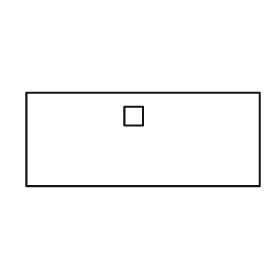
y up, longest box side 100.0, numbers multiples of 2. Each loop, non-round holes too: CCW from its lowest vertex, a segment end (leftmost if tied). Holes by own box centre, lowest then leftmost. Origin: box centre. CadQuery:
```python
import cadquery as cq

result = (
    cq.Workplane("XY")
    .moveTo(-50.0, -20.0)
    .lineTo(50.0, -20.0)
    .lineTo(50.0, 20.0)
    .lineTo(-50.0, 20.0)
    .close()
    .moveTo(-8.0, 6.0)
    .lineTo(0.0, 6.0)
    .lineTo(0.0, 14.0)
    .lineTo(-8.0, 14.0)
    .close()
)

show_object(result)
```